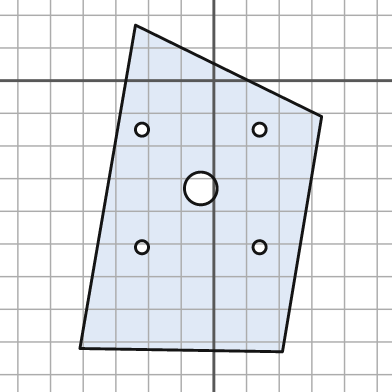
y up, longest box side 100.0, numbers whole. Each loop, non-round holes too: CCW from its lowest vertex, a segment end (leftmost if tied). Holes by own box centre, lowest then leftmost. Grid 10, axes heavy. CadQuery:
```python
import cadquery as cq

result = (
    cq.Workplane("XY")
    .moveTo(21.0, -83.0)
    .lineTo(33.0, -11.0)
    .lineTo(-24.0, 17.0)
    .lineTo(-41.0, -82.0)
    .close()
    .moveTo(-22.0, -51.0)
    .circle(2.0)
    .moveTo(14.0, -51.0)
    .circle(2.0)
    .moveTo(-4.0, -33.0)
    .circle(5.0)
    .moveTo(-22.0, -15.0)
    .circle(2.0)
    .moveTo(14.0, -15.0)
    .circle(2.0)
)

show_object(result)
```